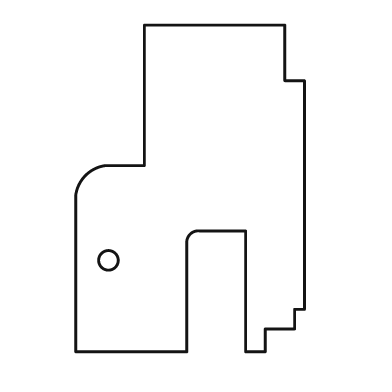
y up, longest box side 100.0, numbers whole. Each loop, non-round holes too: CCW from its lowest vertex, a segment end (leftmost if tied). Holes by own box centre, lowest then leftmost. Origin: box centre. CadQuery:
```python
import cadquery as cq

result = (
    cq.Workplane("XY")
    .moveTo(-35.0, -50.0)
    .lineTo(-1.0, -50.0)
    .lineTo(-1.0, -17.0)
    .threePointArc((0.0, -14.0), (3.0, -13.0))
    .lineTo(17.0, -13.0)
    .lineTo(17.0, -50.0)
    .lineTo(23.0, -50.0)
    .lineTo(23.0, -43.0)
    .lineTo(32.0, -43.0)
    .lineTo(32.0, -37.0)
    .lineTo(35.0, -37.0)
    .lineTo(35.0, 33.0)
    .lineTo(29.0, 33.0)
    .lineTo(29.0, 50.0)
    .lineTo(-14.0, 50.0)
    .lineTo(-14.0, 7.0)
    .lineTo(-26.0, 7.0)
    .threePointArc((-32.0, 4.0), (-35.0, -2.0))
    .close()
    .moveTo(-25.0, -22.0)
    .circle(3.0)
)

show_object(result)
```